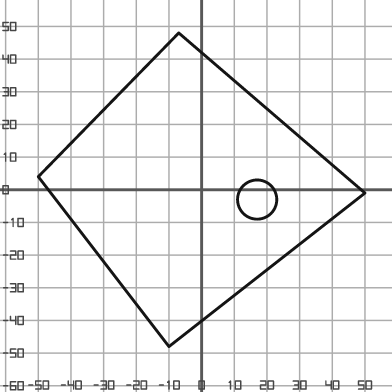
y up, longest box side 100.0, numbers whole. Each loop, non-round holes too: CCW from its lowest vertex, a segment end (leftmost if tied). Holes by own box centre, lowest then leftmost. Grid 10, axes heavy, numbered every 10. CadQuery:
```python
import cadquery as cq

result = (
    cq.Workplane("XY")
    .moveTo(-10.0, -48.0)
    .lineTo(50.0, -1.0)
    .lineTo(-7.0, 48.0)
    .lineTo(-50.0, 4.0)
    .close()
    .moveTo(17.0, -3.0)
    .circle(6.0)
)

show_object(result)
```